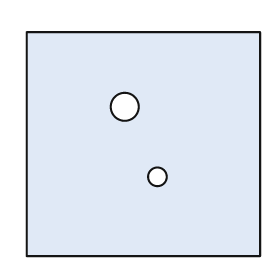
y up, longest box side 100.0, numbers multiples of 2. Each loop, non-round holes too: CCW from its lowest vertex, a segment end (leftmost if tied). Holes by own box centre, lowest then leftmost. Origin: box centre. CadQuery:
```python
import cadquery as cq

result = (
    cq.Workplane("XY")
    .moveTo(-50.0, -48.0)
    .lineTo(50.0, -48.0)
    .lineTo(50.0, 48.0)
    .lineTo(-50.0, 48.0)
    .close()
    .moveTo(6.0, -14.0)
    .circle(4.0)
    .moveTo(-8.0, 16.0)
    .circle(6.0)
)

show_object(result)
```